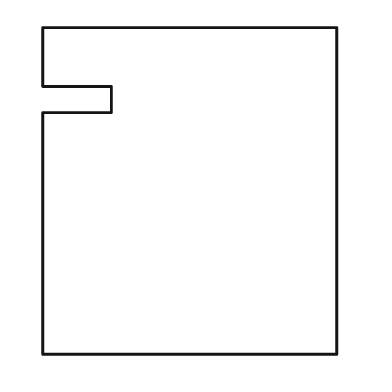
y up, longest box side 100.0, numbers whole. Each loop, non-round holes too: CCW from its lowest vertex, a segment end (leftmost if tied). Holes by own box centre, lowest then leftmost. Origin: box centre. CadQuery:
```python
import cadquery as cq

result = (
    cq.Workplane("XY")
    .moveTo(-45.0, -50.0)
    .lineTo(45.0, -50.0)
    .lineTo(45.0, 50.0)
    .lineTo(-45.0, 50.0)
    .lineTo(-45.0, 32.0)
    .lineTo(-24.0, 32.0)
    .lineTo(-24.0, 24.0)
    .lineTo(-45.0, 24.0)
    .close()
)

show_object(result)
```